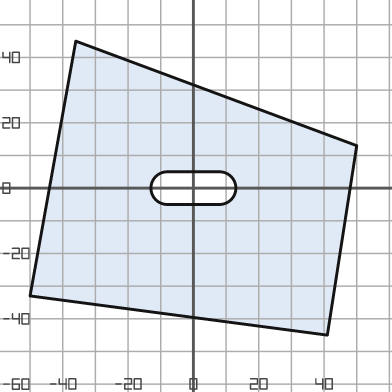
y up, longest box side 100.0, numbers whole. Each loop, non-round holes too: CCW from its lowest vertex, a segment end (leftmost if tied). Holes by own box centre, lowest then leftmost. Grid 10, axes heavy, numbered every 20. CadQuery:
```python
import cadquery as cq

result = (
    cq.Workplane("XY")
    .moveTo(41.0, -45.0)
    .lineTo(50.0, 13.0)
    .lineTo(-36.0, 45.0)
    .lineTo(-50.0, -33.0)
    .close()
    .moveTo(-8.0, -5.0)
    .lineTo(8.0, -5.0)
    .threePointArc((13.0, 0.0), (8.0, 5.0))
    .lineTo(-8.0, 5.0)
    .threePointArc((-13.0, 0.0), (-8.0, -5.0))
    .close()
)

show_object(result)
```